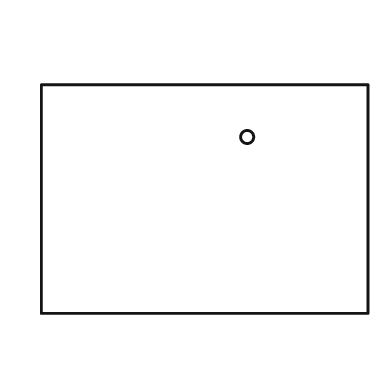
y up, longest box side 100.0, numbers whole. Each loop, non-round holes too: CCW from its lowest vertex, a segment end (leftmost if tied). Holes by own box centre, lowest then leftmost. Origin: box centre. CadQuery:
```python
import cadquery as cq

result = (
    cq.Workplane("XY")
    .moveTo(-50.0, -35.0)
    .lineTo(50.0, -35.0)
    .lineTo(50.0, 35.0)
    .lineTo(-50.0, 35.0)
    .close()
    .moveTo(13.0, 19.0)
    .circle(2.0)
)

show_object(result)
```